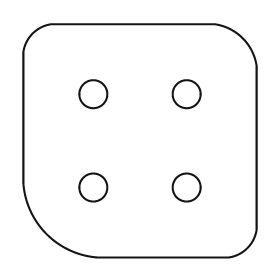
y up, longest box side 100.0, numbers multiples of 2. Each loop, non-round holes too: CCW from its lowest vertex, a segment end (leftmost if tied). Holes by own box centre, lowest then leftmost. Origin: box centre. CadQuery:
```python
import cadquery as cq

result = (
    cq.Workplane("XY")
    .moveTo(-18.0, -50.0)
    .lineTo(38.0, -50.0)
    .threePointArc((46.0, -46.0), (50.0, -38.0))
    .lineTo(50.0, 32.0)
    .threePointArc((44.0, 44.0), (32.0, 50.0))
    .lineTo(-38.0, 50.0)
    .threePointArc((-46.0, 46.0), (-50.0, 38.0))
    .lineTo(-50.0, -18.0)
    .threePointArc((-40.0, -40.0), (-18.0, -50.0))
    .close()
    .moveTo(-20.0, -20.0)
    .circle(6.0)
    .moveTo(20.0, -20.0)
    .circle(6.0)
    .moveTo(-20.0, 20.0)
    .circle(6.0)
    .moveTo(20.0, 20.0)
    .circle(6.0)
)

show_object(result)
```